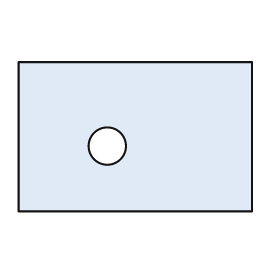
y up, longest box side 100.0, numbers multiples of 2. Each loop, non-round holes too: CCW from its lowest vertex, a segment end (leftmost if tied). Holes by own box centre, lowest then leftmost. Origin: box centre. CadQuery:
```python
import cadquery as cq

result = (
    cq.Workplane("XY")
    .moveTo(-50.0, -32.0)
    .lineTo(50.0, -32.0)
    .lineTo(50.0, 32.0)
    .lineTo(-50.0, 32.0)
    .close()
    .moveTo(-12.0, -4.0)
    .circle(8.0)
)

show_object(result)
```